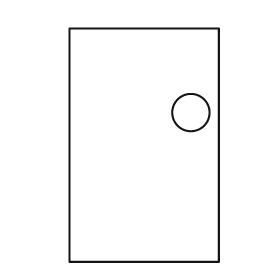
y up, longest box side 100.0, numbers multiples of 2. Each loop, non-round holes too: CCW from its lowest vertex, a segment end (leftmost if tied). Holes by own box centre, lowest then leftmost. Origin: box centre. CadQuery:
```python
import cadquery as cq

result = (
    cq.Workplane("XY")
    .moveTo(-32.0, -50.0)
    .lineTo(32.0, -50.0)
    .lineTo(32.0, 50.0)
    .lineTo(-32.0, 50.0)
    .close()
    .moveTo(20.0, 14.0)
    .circle(8.0)
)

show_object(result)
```